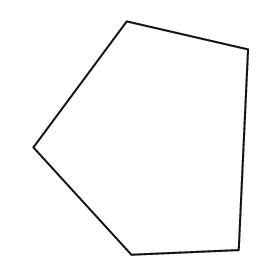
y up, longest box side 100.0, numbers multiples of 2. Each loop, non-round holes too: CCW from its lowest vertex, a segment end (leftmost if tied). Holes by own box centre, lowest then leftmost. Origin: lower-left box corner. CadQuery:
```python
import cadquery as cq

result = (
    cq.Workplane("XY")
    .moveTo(42.0, 0.0)
    .lineTo(88.0, 2.0)
    .lineTo(92.0, 88.0)
    .lineTo(40.0, 100.0)
    .lineTo(0.0, 46.0)
    .close()
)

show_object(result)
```